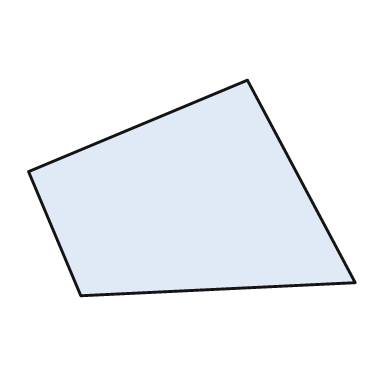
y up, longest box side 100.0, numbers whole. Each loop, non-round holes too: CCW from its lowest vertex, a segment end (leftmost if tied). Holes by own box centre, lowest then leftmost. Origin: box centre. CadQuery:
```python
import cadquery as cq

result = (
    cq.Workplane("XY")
    .moveTo(-34.0, -33.0)
    .lineTo(50.0, -29.0)
    .lineTo(17.0, 33.0)
    .lineTo(-50.0, 5.0)
    .close()
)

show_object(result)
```